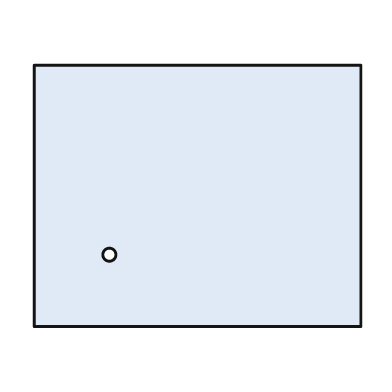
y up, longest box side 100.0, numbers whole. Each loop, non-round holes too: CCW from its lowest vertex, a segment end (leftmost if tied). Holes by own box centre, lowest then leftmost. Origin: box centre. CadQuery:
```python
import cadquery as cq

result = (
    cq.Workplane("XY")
    .moveTo(-50.0, -40.0)
    .lineTo(50.0, -40.0)
    .lineTo(50.0, 40.0)
    .lineTo(-50.0, 40.0)
    .close()
    .moveTo(-27.0, -18.0)
    .circle(2.0)
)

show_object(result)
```